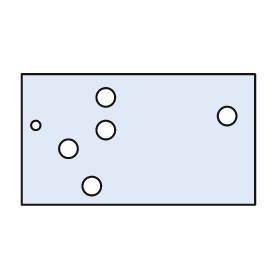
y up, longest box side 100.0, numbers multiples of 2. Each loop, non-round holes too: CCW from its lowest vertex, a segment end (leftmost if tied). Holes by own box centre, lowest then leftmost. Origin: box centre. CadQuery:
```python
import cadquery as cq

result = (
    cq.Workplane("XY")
    .moveTo(-50.0, -28.0)
    .lineTo(50.0, -28.0)
    .lineTo(50.0, 28.0)
    .lineTo(-50.0, 28.0)
    .close()
    .moveTo(-20.0, -20.0)
    .circle(4.0)
    .moveTo(-30.0, -4.0)
    .circle(4.0)
    .moveTo(-14.0, 4.0)
    .circle(4.0)
    .moveTo(-44.0, 6.0)
    .circle(2.0)
    .moveTo(38.0, 10.0)
    .circle(4.0)
    .moveTo(-14.0, 18.0)
    .circle(4.0)
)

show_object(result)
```